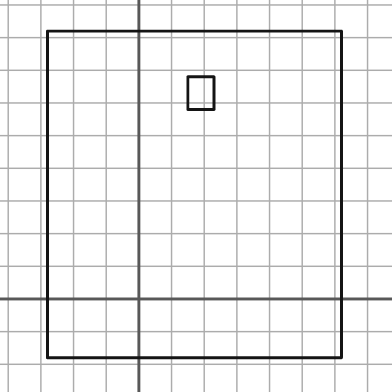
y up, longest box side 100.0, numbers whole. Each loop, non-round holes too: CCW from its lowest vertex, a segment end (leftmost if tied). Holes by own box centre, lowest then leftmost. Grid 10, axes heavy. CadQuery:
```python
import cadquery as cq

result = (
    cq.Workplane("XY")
    .moveTo(-28.0, -18.0)
    .lineTo(62.0, -18.0)
    .lineTo(62.0, 82.0)
    .lineTo(-28.0, 82.0)
    .close()
    .moveTo(15.0, 58.0)
    .lineTo(23.0, 58.0)
    .lineTo(23.0, 68.0)
    .lineTo(15.0, 68.0)
    .close()
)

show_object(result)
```